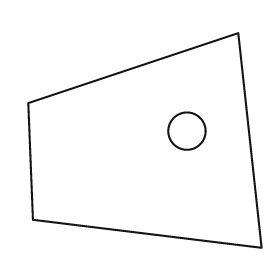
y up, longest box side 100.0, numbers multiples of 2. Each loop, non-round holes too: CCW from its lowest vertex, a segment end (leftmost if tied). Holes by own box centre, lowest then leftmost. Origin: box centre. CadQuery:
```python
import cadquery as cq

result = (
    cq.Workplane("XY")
    .moveTo(50.0, -46.0)
    .lineTo(40.0, 46.0)
    .lineTo(-50.0, 16.0)
    .lineTo(-48.0, -34.0)
    .close()
    .moveTo(18.0, 4.0)
    .circle(8.0)
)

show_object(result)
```